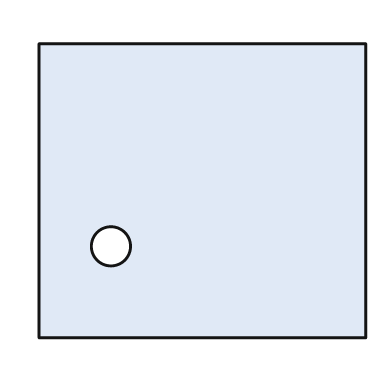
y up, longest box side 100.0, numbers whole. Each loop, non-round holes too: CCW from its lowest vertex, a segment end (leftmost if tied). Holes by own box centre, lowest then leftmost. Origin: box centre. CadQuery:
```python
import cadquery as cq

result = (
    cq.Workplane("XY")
    .moveTo(-50.0, -45.0)
    .lineTo(50.0, -45.0)
    .lineTo(50.0, 45.0)
    .lineTo(-50.0, 45.0)
    .close()
    .moveTo(-28.0, -17.0)
    .circle(6.0)
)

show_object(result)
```